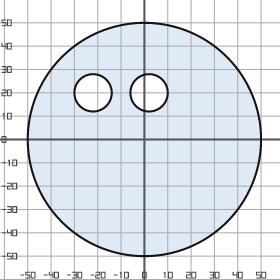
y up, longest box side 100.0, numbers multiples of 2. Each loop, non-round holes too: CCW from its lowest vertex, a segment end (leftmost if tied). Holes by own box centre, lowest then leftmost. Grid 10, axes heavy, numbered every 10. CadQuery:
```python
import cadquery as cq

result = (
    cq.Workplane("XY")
    .moveTo(0.0, 0.0)
    .circle(50.0)
    .moveTo(-22.0, 20.0)
    .circle(8.0)
    .moveTo(2.0, 20.0)
    .circle(8.0)
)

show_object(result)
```